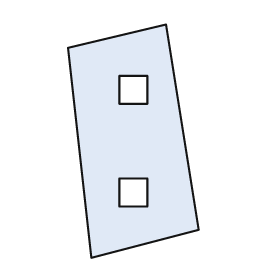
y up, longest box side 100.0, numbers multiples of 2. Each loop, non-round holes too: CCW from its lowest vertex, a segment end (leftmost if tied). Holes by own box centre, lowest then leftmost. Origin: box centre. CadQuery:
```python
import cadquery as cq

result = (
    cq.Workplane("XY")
    .moveTo(-18.0, -50.0)
    .lineTo(28.0, -38.0)
    .lineTo(14.0, 50.0)
    .lineTo(-28.0, 40.0)
    .close()
    .moveTo(-6.0, -28.0)
    .lineTo(6.0, -28.0)
    .lineTo(6.0, -16.0)
    .lineTo(-6.0, -16.0)
    .close()
    .moveTo(-6.0, 16.0)
    .lineTo(6.0, 16.0)
    .lineTo(6.0, 28.0)
    .lineTo(-6.0, 28.0)
    .close()
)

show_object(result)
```